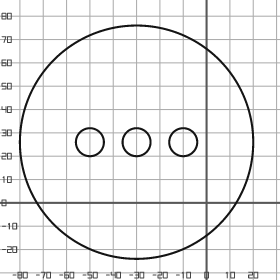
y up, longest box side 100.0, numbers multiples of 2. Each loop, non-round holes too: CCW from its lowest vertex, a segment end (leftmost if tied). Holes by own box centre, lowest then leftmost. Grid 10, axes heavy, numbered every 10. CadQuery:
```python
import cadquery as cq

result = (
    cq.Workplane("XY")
    .moveTo(-30.0, 26.0)
    .circle(50.0)
    .moveTo(-50.0, 26.0)
    .circle(6.0)
    .moveTo(-30.0, 26.0)
    .circle(6.0)
    .moveTo(-10.0, 26.0)
    .circle(6.0)
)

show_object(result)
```